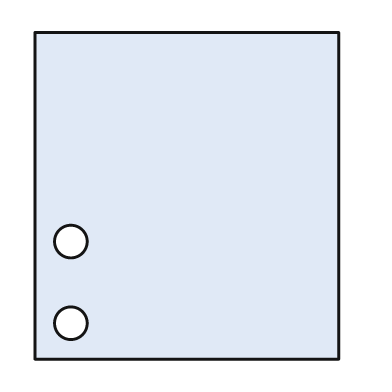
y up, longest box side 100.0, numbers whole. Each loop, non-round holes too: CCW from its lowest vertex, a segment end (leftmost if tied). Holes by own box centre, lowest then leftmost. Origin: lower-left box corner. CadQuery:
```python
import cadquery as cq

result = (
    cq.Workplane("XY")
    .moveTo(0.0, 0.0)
    .lineTo(93.0, 0.0)
    .lineTo(93.0, 100.0)
    .lineTo(0.0, 100.0)
    .close()
    .moveTo(11.0, 11.0)
    .circle(5.0)
    .moveTo(11.0, 36.0)
    .circle(5.0)
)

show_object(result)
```